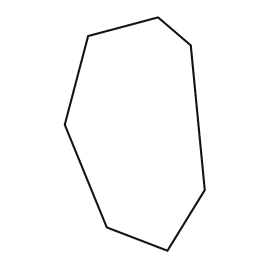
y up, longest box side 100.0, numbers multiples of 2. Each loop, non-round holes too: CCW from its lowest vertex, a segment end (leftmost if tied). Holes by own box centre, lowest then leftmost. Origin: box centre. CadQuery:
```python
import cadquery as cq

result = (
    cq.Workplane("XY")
    .moveTo(14.0, -50.0)
    .lineTo(30.0, -24.0)
    .lineTo(24.0, 38.0)
    .lineTo(10.0, 50.0)
    .lineTo(-20.0, 42.0)
    .lineTo(-30.0, 4.0)
    .lineTo(-12.0, -40.0)
    .close()
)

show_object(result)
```